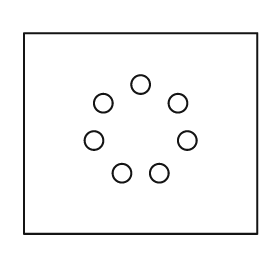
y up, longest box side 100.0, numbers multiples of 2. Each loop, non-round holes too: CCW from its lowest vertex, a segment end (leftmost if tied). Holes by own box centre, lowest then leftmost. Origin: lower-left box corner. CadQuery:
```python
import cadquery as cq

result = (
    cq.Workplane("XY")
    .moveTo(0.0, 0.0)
    .lineTo(100.0, 0.0)
    .lineTo(100.0, 86.0)
    .lineTo(0.0, 86.0)
    .close()
    .moveTo(42.0, 26.0)
    .circle(4.0)
    .moveTo(58.0, 26.0)
    .circle(4.0)
    .moveTo(30.0, 40.0)
    .circle(4.0)
    .moveTo(70.0, 40.0)
    .circle(4.0)
    .moveTo(34.0, 56.0)
    .circle(4.0)
    .moveTo(66.0, 56.0)
    .circle(4.0)
    .moveTo(50.0, 64.0)
    .circle(4.0)
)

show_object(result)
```